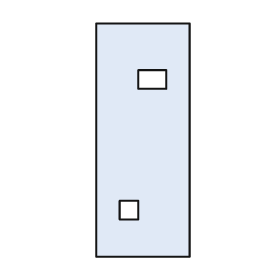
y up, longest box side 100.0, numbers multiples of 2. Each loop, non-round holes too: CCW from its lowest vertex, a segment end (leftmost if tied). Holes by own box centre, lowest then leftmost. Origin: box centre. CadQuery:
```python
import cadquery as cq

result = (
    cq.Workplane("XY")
    .moveTo(-20.0, -50.0)
    .lineTo(20.0, -50.0)
    .lineTo(20.0, 50.0)
    .lineTo(-20.0, 50.0)
    .close()
    .moveTo(-10.0, -34.0)
    .lineTo(-2.0, -34.0)
    .lineTo(-2.0, -26.0)
    .lineTo(-10.0, -26.0)
    .close()
    .moveTo(-2.0, 22.0)
    .lineTo(10.0, 22.0)
    .lineTo(10.0, 30.0)
    .lineTo(-2.0, 30.0)
    .close()
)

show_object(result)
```